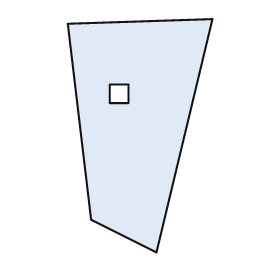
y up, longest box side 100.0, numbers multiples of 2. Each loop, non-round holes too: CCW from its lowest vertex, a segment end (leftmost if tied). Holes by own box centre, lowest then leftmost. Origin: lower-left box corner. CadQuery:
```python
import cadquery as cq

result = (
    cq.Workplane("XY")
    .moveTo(38.0, 0.0)
    .lineTo(62.0, 100.0)
    .lineTo(0.0, 98.0)
    .lineTo(10.0, 14.0)
    .close()
    .moveTo(18.0, 64.0)
    .lineTo(26.0, 64.0)
    .lineTo(26.0, 72.0)
    .lineTo(18.0, 72.0)
    .close()
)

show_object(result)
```